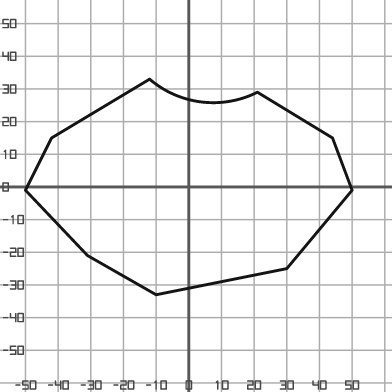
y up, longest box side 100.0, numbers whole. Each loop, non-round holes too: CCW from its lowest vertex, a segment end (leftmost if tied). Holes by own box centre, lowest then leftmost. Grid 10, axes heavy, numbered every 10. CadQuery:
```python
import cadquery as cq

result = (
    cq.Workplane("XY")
    .moveTo(-10.0, -33.0)
    .lineTo(30.0, -25.0)
    .lineTo(50.0, -1.0)
    .lineTo(44.0, 15.0)
    .lineTo(21.0, 29.0)
    .threePointArc((4.0, 26.0), (-12.0, 33.0))
    .lineTo(-42.0, 15.0)
    .lineTo(-50.0, -1.0)
    .lineTo(-31.0, -21.0)
    .close()
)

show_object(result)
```